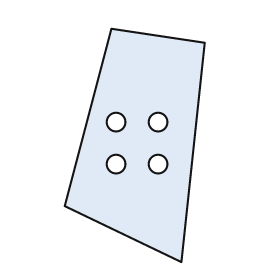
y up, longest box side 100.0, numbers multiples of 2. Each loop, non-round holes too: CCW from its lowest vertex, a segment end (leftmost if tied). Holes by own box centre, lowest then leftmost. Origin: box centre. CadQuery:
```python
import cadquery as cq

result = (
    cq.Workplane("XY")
    .moveTo(20.0, -50.0)
    .lineTo(30.0, 44.0)
    .lineTo(-10.0, 50.0)
    .lineTo(-30.0, -26.0)
    .close()
    .moveTo(-8.0, -8.0)
    .circle(4.0)
    .moveTo(10.0, -8.0)
    .circle(4.0)
    .moveTo(-8.0, 10.0)
    .circle(4.0)
    .moveTo(10.0, 10.0)
    .circle(4.0)
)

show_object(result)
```